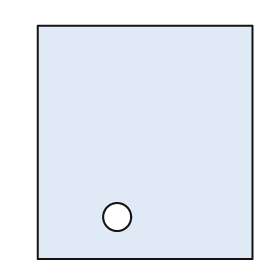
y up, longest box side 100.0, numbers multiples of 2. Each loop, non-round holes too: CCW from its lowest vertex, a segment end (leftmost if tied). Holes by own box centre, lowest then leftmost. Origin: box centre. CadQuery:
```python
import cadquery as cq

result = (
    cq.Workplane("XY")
    .moveTo(-46.0, -50.0)
    .lineTo(46.0, -50.0)
    .lineTo(46.0, 50.0)
    .lineTo(-46.0, 50.0)
    .close()
    .moveTo(-12.0, -32.0)
    .circle(6.0)
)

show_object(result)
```